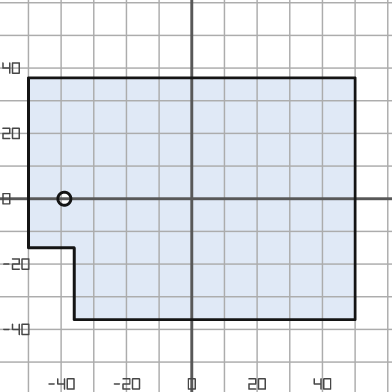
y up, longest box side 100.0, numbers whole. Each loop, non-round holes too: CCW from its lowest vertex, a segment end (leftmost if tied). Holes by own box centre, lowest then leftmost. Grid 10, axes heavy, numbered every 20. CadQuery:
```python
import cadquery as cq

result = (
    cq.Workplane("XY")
    .moveTo(-36.0, -37.0)
    .lineTo(50.0, -37.0)
    .lineTo(50.0, 37.0)
    .lineTo(-50.0, 37.0)
    .lineTo(-50.0, -15.0)
    .lineTo(-36.0, -15.0)
    .close()
    .moveTo(-39.0, 0.0)
    .circle(2.0)
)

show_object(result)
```